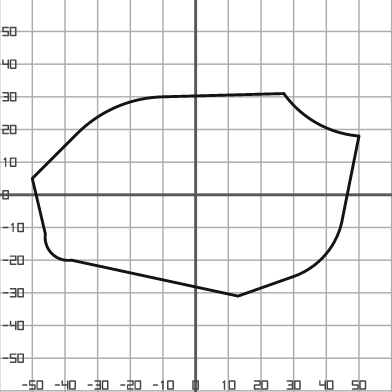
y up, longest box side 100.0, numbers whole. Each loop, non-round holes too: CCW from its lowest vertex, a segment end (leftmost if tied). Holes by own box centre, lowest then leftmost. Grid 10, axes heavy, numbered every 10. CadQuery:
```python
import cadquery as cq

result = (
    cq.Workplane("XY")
    .moveTo(13.0, -31.0)
    .lineTo(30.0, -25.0)
    .threePointArc((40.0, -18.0), (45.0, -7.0))
    .lineTo(50.0, 18.0)
    .threePointArc((37.0, 22.0), (27.0, 31.0))
    .lineTo(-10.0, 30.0)
    .threePointArc((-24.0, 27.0), (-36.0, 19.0))
    .lineTo(-50.0, 5.0)
    .lineTo(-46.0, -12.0)
    .threePointArc((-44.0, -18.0), (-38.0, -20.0))
    .close()
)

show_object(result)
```